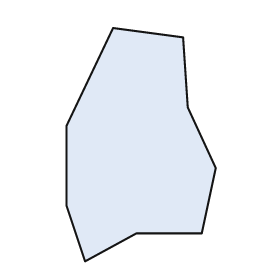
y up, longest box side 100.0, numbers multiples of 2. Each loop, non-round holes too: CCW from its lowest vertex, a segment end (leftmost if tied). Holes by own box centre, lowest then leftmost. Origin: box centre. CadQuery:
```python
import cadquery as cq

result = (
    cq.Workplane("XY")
    .moveTo(-24.0, -50.0)
    .lineTo(-2.0, -38.0)
    .lineTo(26.0, -38.0)
    .lineTo(32.0, -10.0)
    .lineTo(20.0, 16.0)
    .lineTo(18.0, 46.0)
    .lineTo(-12.0, 50.0)
    .lineTo(-32.0, 8.0)
    .lineTo(-32.0, -26.0)
    .close()
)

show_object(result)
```